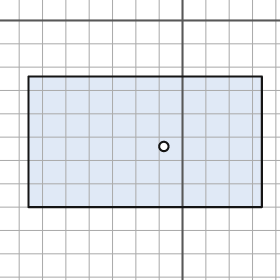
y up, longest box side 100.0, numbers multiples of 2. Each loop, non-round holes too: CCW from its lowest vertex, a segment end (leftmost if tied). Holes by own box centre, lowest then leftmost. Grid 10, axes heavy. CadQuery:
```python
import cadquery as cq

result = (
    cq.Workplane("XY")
    .moveTo(-66.0, -80.0)
    .lineTo(34.0, -80.0)
    .lineTo(34.0, -24.0)
    .lineTo(-66.0, -24.0)
    .close()
    .moveTo(-8.0, -54.0)
    .circle(2.0)
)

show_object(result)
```